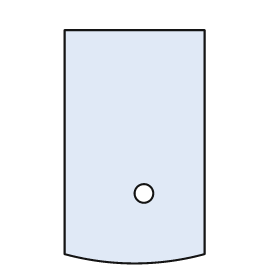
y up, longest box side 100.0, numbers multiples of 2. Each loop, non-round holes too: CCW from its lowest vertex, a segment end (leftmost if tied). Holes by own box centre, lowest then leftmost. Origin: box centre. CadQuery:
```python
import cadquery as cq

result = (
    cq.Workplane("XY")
    .moveTo(-30.0, -46.0)
    .threePointArc((0.0, -50.0), (30.0, -46.0))
    .lineTo(30.0, 50.0)
    .lineTo(-30.0, 50.0)
    .close()
    .moveTo(4.0, -20.0)
    .circle(4.0)
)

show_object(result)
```